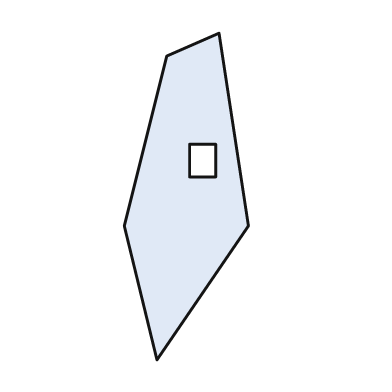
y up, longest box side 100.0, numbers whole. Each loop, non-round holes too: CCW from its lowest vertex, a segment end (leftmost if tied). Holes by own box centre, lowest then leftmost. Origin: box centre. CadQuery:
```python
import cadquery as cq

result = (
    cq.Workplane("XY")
    .moveTo(-9.0, -50.0)
    .lineTo(19.0, -9.0)
    .lineTo(10.0, 50.0)
    .lineTo(-6.0, 43.0)
    .lineTo(-19.0, -9.0)
    .close()
    .moveTo(1.0, 6.0)
    .lineTo(9.0, 6.0)
    .lineTo(9.0, 16.0)
    .lineTo(1.0, 16.0)
    .close()
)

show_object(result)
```